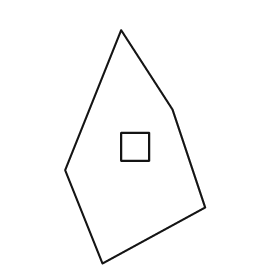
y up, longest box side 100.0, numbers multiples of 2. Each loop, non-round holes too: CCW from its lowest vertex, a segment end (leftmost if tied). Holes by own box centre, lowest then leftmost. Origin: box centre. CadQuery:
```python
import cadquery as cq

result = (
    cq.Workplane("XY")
    .moveTo(-14.0, -50.0)
    .lineTo(30.0, -26.0)
    .lineTo(16.0, 16.0)
    .lineTo(-6.0, 50.0)
    .lineTo(-30.0, -10.0)
    .close()
    .moveTo(-6.0, -6.0)
    .lineTo(6.0, -6.0)
    .lineTo(6.0, 6.0)
    .lineTo(-6.0, 6.0)
    .close()
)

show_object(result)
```